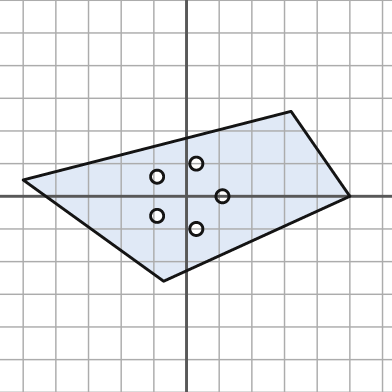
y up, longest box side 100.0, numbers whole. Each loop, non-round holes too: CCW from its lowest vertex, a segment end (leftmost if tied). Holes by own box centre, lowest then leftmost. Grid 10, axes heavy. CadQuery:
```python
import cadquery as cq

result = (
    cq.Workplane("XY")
    .moveTo(-7.0, -26.0)
    .lineTo(50.0, 0.0)
    .lineTo(32.0, 26.0)
    .lineTo(-50.0, 5.0)
    .close()
    .moveTo(3.0, -10.0)
    .circle(2.0)
    .moveTo(-9.0, -6.0)
    .circle(2.0)
    .moveTo(11.0, 0.0)
    .circle(2.0)
    .moveTo(-9.0, 6.0)
    .circle(2.0)
    .moveTo(3.0, 10.0)
    .circle(2.0)
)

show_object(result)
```